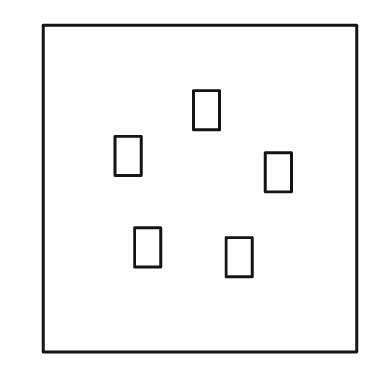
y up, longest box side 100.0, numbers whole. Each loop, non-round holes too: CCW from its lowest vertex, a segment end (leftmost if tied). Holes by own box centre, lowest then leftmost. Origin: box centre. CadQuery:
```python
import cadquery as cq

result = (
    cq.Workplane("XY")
    .moveTo(-48.0, -50.0)
    .lineTo(48.0, -50.0)
    .lineTo(48.0, 50.0)
    .lineTo(-48.0, 50.0)
    .close()
    .moveTo(8.0, -27.0)
    .lineTo(16.0, -27.0)
    .lineTo(16.0, -15.0)
    .lineTo(8.0, -15.0)
    .close()
    .moveTo(-20.0, -24.0)
    .lineTo(-12.0, -24.0)
    .lineTo(-12.0, -12.0)
    .lineTo(-20.0, -12.0)
    .close()
    .moveTo(20.0, -1.0)
    .lineTo(28.0, -1.0)
    .lineTo(28.0, 11.0)
    .lineTo(20.0, 11.0)
    .close()
    .moveTo(-26.0, 4.0)
    .lineTo(-18.0, 4.0)
    .lineTo(-18.0, 16.0)
    .lineTo(-26.0, 16.0)
    .close()
    .moveTo(-2.0, 18.0)
    .lineTo(6.0, 18.0)
    .lineTo(6.0, 30.0)
    .lineTo(-2.0, 30.0)
    .close()
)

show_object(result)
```